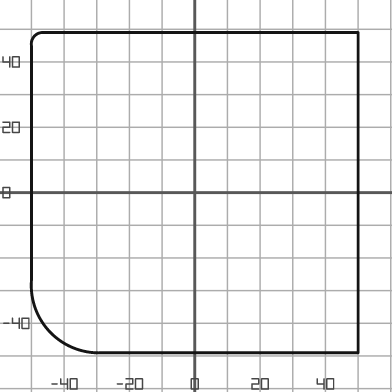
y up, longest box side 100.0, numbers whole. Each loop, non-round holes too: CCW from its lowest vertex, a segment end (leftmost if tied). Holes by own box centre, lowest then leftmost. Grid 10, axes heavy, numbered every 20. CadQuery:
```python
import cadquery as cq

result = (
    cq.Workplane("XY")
    .moveTo(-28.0, -49.0)
    .lineTo(50.0, -49.0)
    .lineTo(50.0, 49.0)
    .lineTo(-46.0, 49.0)
    .threePointArc((-49.0, 48.0), (-50.0, 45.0))
    .lineTo(-50.0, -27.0)
    .threePointArc((-44.0, -43.0), (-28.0, -49.0))
    .close()
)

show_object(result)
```